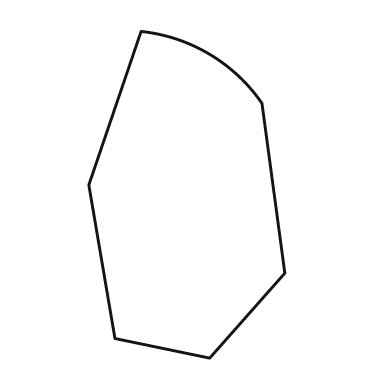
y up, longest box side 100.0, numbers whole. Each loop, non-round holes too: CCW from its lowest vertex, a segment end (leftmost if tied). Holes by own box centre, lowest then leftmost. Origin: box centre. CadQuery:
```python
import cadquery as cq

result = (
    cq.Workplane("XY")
    .moveTo(7.0, -50.0)
    .lineTo(30.0, -24.0)
    .lineTo(23.0, 28.0)
    .threePointArc((7.0, 43.0), (-14.0, 50.0))
    .lineTo(-30.0, 3.0)
    .lineTo(-22.0, -44.0)
    .close()
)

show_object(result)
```